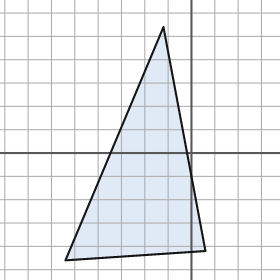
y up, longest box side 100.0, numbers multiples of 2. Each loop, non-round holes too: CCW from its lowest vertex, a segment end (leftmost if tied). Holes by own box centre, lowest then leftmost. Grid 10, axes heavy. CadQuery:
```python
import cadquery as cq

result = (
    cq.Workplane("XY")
    .moveTo(-54.0, -46.0)
    .lineTo(6.0, -42.0)
    .lineTo(-12.0, 54.0)
    .close()
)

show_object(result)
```